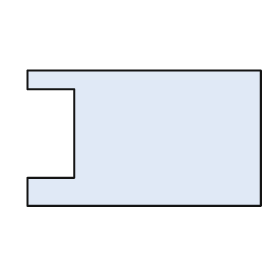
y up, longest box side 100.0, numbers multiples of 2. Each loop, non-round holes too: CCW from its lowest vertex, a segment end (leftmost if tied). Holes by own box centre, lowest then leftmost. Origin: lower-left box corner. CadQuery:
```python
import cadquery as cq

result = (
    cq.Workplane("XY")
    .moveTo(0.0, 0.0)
    .lineTo(100.0, 0.0)
    .lineTo(100.0, 58.0)
    .lineTo(0.0, 58.0)
    .lineTo(0.0, 50.0)
    .lineTo(20.0, 50.0)
    .lineTo(20.0, 12.0)
    .lineTo(0.0, 12.0)
    .close()
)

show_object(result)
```